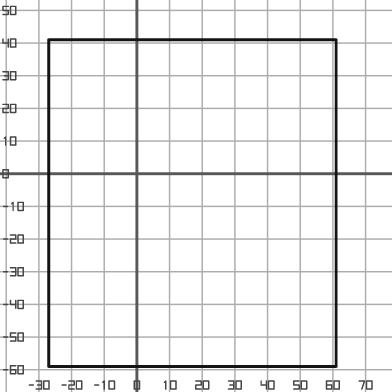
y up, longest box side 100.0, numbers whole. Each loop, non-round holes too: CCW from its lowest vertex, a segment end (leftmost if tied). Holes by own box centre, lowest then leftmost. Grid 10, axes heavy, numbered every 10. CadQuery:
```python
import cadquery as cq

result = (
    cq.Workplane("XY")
    .moveTo(-27.0, -59.0)
    .lineTo(61.0, -59.0)
    .lineTo(61.0, 41.0)
    .lineTo(-27.0, 41.0)
    .close()
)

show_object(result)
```